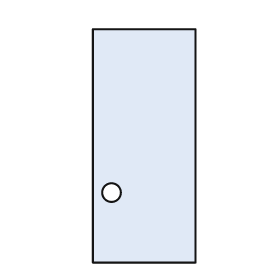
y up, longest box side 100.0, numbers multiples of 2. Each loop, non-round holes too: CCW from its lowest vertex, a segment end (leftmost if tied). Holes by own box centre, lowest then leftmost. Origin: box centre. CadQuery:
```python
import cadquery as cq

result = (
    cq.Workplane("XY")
    .moveTo(-22.0, -50.0)
    .lineTo(22.0, -50.0)
    .lineTo(22.0, 50.0)
    .lineTo(-22.0, 50.0)
    .close()
    .moveTo(-14.0, -20.0)
    .circle(4.0)
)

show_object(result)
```